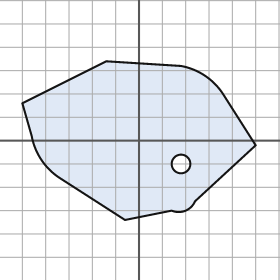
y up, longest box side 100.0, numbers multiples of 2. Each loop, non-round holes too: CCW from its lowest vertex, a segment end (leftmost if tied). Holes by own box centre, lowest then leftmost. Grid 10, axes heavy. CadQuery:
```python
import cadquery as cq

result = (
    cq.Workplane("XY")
    .moveTo(-6.0, -34.0)
    .lineTo(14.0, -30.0)
    .threePointArc((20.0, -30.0), (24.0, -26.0))
    .lineTo(50.0, -2.0)
    .lineTo(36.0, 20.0)
    .threePointArc((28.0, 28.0), (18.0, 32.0))
    .lineTo(-14.0, 34.0)
    .lineTo(-50.0, 16.0)
    .lineTo(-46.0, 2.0)
    .threePointArc((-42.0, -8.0), (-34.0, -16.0))
    .close()
    .moveTo(18.0, -10.0)
    .circle(4.0)
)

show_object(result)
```